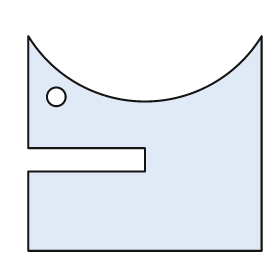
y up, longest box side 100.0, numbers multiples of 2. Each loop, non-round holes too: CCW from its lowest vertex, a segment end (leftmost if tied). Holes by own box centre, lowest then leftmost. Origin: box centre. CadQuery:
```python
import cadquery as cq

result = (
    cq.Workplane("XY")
    .moveTo(-50.0, -46.0)
    .lineTo(50.0, -46.0)
    .lineTo(50.0, 46.0)
    .threePointArc((0.0, 18.0), (-50.0, 46.0))
    .lineTo(-50.0, -2.0)
    .lineTo(0.0, -2.0)
    .lineTo(0.0, -12.0)
    .lineTo(-50.0, -12.0)
    .close()
    .moveTo(-38.0, 20.0)
    .circle(4.0)
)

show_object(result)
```